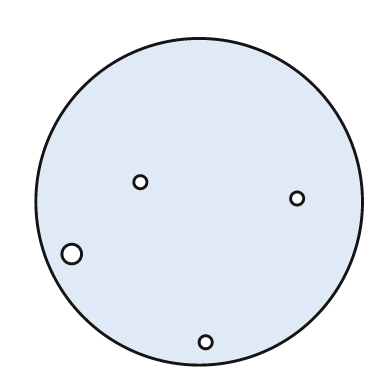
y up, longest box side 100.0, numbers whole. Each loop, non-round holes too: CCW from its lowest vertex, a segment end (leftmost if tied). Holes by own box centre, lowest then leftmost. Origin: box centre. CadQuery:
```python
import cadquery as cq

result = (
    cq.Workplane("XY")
    .moveTo(0.0, 0.0)
    .circle(50.0)
    .moveTo(2.0, -43.0)
    .circle(2.0)
    .moveTo(-39.0, -16.0)
    .circle(3.0)
    .moveTo(30.0, 1.0)
    .circle(2.0)
    .moveTo(-18.0, 6.0)
    .circle(2.0)
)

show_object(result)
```